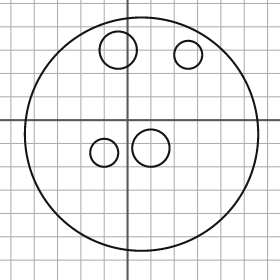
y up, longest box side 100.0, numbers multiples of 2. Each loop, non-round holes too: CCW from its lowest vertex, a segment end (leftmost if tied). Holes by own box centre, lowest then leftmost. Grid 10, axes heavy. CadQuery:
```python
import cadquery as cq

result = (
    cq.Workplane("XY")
    .moveTo(6.0, -6.0)
    .circle(50.0)
    .moveTo(-10.0, -14.0)
    .circle(6.0)
    .moveTo(10.0, -12.0)
    .circle(8.0)
    .moveTo(26.0, 28.0)
    .circle(6.0)
    .moveTo(-4.0, 30.0)
    .circle(8.0)
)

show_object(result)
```